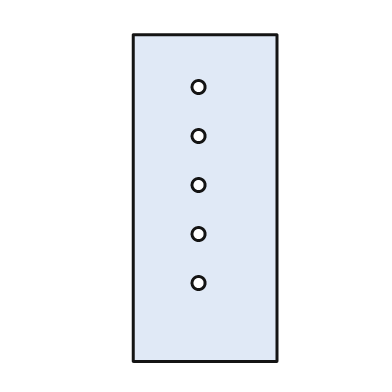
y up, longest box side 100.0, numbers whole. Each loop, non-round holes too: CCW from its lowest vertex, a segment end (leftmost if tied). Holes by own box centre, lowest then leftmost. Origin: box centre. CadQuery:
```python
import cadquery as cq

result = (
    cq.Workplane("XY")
    .moveTo(-22.0, -50.0)
    .lineTo(22.0, -50.0)
    .lineTo(22.0, 50.0)
    .lineTo(-22.0, 50.0)
    .close()
    .moveTo(-2.0, -26.0)
    .circle(2.0)
    .moveTo(-2.0, -11.0)
    .circle(2.0)
    .moveTo(-2.0, 4.0)
    .circle(2.0)
    .moveTo(-2.0, 19.0)
    .circle(2.0)
    .moveTo(-2.0, 34.0)
    .circle(2.0)
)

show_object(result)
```